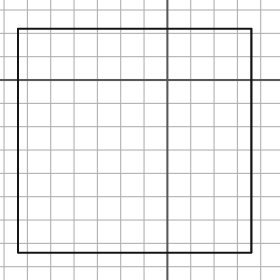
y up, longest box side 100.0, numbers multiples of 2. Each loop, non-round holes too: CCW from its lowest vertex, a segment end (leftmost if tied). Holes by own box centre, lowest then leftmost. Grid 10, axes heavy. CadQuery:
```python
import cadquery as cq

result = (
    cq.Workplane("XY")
    .moveTo(-64.0, -74.0)
    .lineTo(36.0, -74.0)
    .lineTo(36.0, 22.0)
    .lineTo(-64.0, 22.0)
    .close()
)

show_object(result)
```